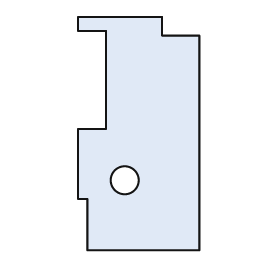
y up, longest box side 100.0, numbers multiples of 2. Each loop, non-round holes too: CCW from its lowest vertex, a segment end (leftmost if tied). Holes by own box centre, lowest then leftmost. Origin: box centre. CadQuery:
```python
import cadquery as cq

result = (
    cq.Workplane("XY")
    .moveTo(-22.0, -50.0)
    .lineTo(26.0, -50.0)
    .lineTo(26.0, 42.0)
    .lineTo(10.0, 42.0)
    .lineTo(10.0, 50.0)
    .lineTo(-26.0, 50.0)
    .lineTo(-26.0, 44.0)
    .lineTo(-14.0, 44.0)
    .lineTo(-14.0, 2.0)
    .lineTo(-26.0, 2.0)
    .lineTo(-26.0, -28.0)
    .lineTo(-22.0, -28.0)
    .close()
    .moveTo(-6.0, -20.0)
    .circle(6.0)
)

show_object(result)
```